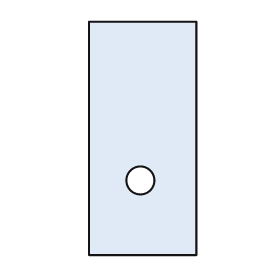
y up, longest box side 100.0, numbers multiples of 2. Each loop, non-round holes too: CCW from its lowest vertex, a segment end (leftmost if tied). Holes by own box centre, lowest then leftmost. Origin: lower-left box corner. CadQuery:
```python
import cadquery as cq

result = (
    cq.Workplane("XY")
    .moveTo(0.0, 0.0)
    .lineTo(46.0, 0.0)
    .lineTo(46.0, 100.0)
    .lineTo(0.0, 100.0)
    .close()
    .moveTo(22.0, 32.0)
    .circle(6.0)
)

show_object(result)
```